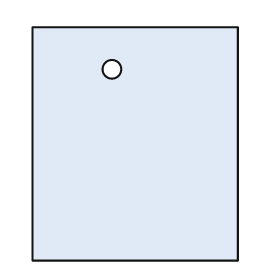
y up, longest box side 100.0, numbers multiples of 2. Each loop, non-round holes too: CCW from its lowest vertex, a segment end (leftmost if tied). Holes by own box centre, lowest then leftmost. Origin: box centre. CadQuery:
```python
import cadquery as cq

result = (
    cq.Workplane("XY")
    .moveTo(-44.0, -50.0)
    .lineTo(44.0, -50.0)
    .lineTo(44.0, 50.0)
    .lineTo(-44.0, 50.0)
    .close()
    .moveTo(-10.0, 32.0)
    .circle(4.0)
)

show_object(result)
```